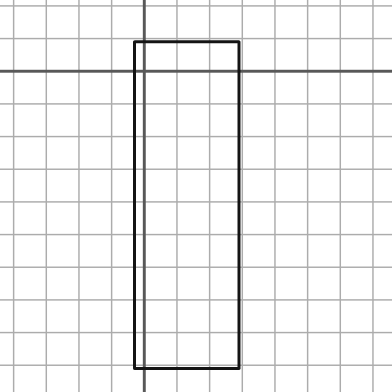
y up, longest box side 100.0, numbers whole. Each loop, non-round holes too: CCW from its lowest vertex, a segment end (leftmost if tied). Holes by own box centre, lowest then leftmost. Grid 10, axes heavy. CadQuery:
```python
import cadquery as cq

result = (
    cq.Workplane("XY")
    .moveTo(-3.0, -91.0)
    .lineTo(29.0, -91.0)
    .lineTo(29.0, 9.0)
    .lineTo(-3.0, 9.0)
    .close()
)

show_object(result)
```